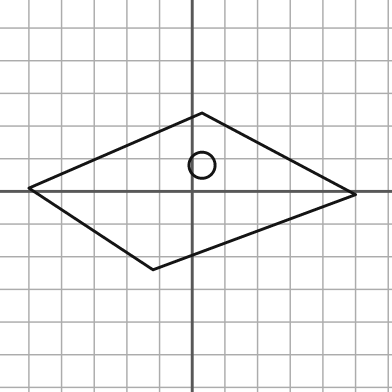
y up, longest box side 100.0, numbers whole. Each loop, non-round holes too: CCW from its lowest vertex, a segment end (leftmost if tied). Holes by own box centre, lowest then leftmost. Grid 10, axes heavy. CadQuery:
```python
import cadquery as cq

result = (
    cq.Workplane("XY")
    .moveTo(-12.0, -24.0)
    .lineTo(50.0, -1.0)
    .lineTo(3.0, 24.0)
    .lineTo(-50.0, 1.0)
    .close()
    .moveTo(3.0, 8.0)
    .circle(4.0)
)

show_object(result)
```